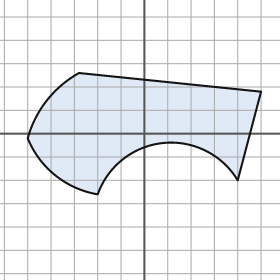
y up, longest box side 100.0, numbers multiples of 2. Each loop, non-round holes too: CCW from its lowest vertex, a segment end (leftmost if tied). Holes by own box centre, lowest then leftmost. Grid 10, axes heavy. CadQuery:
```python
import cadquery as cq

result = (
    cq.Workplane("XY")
    .moveTo(-20.0, -26.0)
    .threePointArc((8.0, -4.0), (40.0, -20.0))
    .lineTo(50.0, 18.0)
    .lineTo(-28.0, 26.0)
    .threePointArc((-42.0, 14.0), (-50.0, -2.0))
    .threePointArc((-38.0, -18.0), (-20.0, -26.0))
    .close()
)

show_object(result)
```